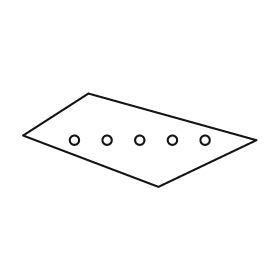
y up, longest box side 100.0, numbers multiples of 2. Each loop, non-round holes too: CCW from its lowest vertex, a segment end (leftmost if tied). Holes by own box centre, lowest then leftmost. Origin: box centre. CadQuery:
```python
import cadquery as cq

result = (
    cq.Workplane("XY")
    .moveTo(8.0, -20.0)
    .lineTo(50.0, 0.0)
    .lineTo(-22.0, 20.0)
    .lineTo(-50.0, 2.0)
    .close()
    .moveTo(-28.0, 0.0)
    .circle(2.0)
    .moveTo(-14.0, 0.0)
    .circle(2.0)
    .moveTo(0.0, 0.0)
    .circle(2.0)
    .moveTo(14.0, 0.0)
    .circle(2.0)
    .moveTo(28.0, 0.0)
    .circle(2.0)
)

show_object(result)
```